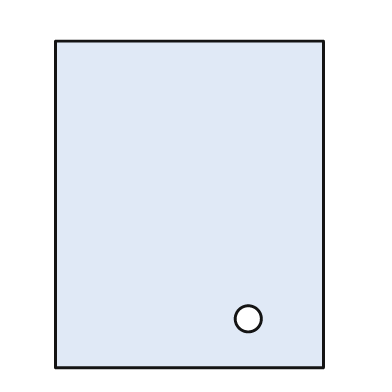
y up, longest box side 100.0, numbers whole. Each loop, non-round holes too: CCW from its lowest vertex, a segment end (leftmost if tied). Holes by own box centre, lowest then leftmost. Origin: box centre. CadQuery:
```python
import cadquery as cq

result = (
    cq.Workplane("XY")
    .moveTo(-41.0, -50.0)
    .lineTo(41.0, -50.0)
    .lineTo(41.0, 50.0)
    .lineTo(-41.0, 50.0)
    .close()
    .moveTo(18.0, -35.0)
    .circle(4.0)
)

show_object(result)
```